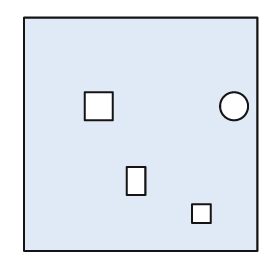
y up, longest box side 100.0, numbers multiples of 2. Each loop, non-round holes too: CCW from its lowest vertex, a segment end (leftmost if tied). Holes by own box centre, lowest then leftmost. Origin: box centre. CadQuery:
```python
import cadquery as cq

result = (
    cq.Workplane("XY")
    .moveTo(-50.0, -50.0)
    .lineTo(50.0, -50.0)
    .lineTo(50.0, 50.0)
    .lineTo(-50.0, 50.0)
    .close()
    .moveTo(22.0, -38.0)
    .lineTo(30.0, -38.0)
    .lineTo(30.0, -30.0)
    .lineTo(22.0, -30.0)
    .close()
    .moveTo(-6.0, -26.0)
    .lineTo(2.0, -26.0)
    .lineTo(2.0, -14.0)
    .lineTo(-6.0, -14.0)
    .close()
    .moveTo(-24.0, 6.0)
    .lineTo(-12.0, 6.0)
    .lineTo(-12.0, 18.0)
    .lineTo(-24.0, 18.0)
    .close()
    .moveTo(40.0, 12.0)
    .circle(6.0)
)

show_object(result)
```